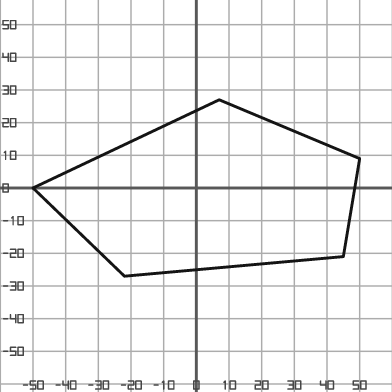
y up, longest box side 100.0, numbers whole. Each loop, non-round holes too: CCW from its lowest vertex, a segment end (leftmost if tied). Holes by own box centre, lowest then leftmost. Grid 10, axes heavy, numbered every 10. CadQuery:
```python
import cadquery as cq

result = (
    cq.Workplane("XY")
    .moveTo(-22.0, -27.0)
    .lineTo(45.0, -21.0)
    .lineTo(50.0, 9.0)
    .lineTo(7.0, 27.0)
    .lineTo(-50.0, 0.0)
    .close()
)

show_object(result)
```